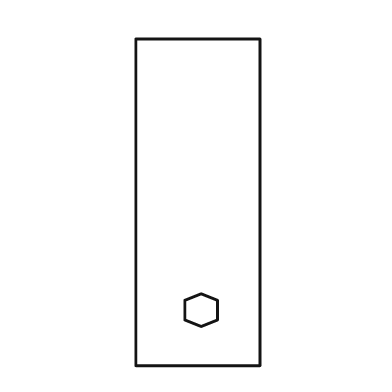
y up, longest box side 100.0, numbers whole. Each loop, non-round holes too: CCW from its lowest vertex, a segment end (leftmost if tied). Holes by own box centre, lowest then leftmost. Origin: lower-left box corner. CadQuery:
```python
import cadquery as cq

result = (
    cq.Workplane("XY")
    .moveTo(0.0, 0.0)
    .lineTo(38.0, 0.0)
    .lineTo(38.0, 100.0)
    .lineTo(0.0, 100.0)
    .close()
    .moveTo(20.0, 12.0)
    .lineTo(25.0, 14.0)
    .lineTo(25.0, 20.0)
    .lineTo(20.0, 22.0)
    .lineTo(15.0, 20.0)
    .lineTo(15.0, 14.0)
    .close()
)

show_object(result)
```